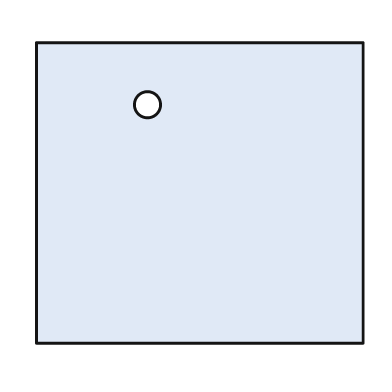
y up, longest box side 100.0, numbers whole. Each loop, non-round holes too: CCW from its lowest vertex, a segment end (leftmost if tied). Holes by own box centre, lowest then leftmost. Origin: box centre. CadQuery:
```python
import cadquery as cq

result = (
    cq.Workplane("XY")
    .moveTo(-50.0, -46.0)
    .lineTo(50.0, -46.0)
    .lineTo(50.0, 46.0)
    .lineTo(-50.0, 46.0)
    .close()
    .moveTo(-16.0, 27.0)
    .circle(4.0)
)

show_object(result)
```